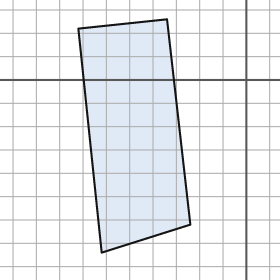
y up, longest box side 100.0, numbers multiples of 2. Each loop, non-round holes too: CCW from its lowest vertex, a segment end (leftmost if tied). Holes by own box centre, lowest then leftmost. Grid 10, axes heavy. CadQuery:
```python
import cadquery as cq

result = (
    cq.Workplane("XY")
    .moveTo(-62.0, -74.0)
    .lineTo(-24.0, -62.0)
    .lineTo(-34.0, 26.0)
    .lineTo(-72.0, 22.0)
    .close()
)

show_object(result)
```